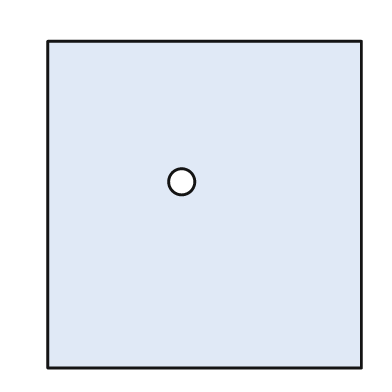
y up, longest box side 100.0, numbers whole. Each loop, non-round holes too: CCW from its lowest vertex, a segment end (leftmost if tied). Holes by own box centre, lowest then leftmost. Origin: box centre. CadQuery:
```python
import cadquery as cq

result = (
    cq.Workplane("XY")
    .moveTo(-48.0, -50.0)
    .lineTo(48.0, -50.0)
    .lineTo(48.0, 50.0)
    .lineTo(-48.0, 50.0)
    .close()
    .moveTo(-7.0, 7.0)
    .circle(4.0)
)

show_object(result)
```